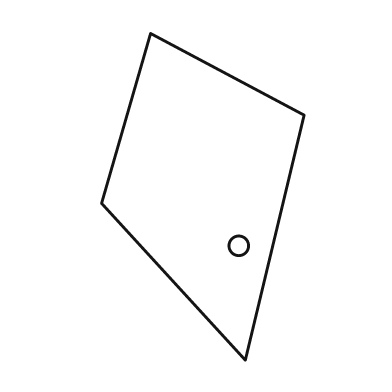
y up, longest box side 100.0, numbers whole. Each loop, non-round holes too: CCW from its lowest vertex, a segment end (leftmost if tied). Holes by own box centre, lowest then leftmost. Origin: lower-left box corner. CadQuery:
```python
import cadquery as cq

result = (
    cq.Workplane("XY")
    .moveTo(44.0, 0.0)
    .lineTo(62.0, 75.0)
    .lineTo(15.0, 100.0)
    .lineTo(0.0, 48.0)
    .close()
    .moveTo(42.0, 35.0)
    .circle(3.0)
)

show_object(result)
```